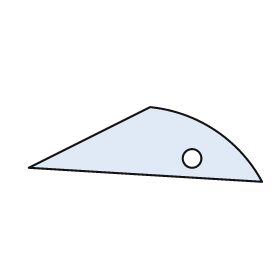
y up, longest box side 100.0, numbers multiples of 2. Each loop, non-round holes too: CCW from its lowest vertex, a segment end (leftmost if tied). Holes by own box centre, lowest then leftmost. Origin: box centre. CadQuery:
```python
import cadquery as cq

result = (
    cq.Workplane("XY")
    .moveTo(50.0, -16.0)
    .threePointArc((30.0, 6.0), (2.0, 16.0))
    .lineTo(-50.0, -10.0)
    .close()
    .moveTo(20.0, -6.0)
    .circle(4.0)
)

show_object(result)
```